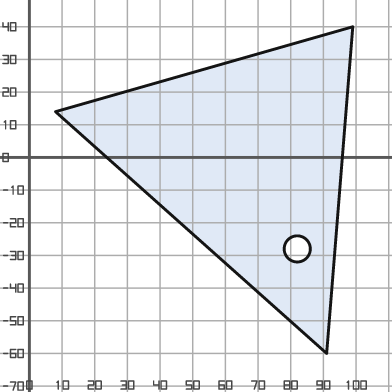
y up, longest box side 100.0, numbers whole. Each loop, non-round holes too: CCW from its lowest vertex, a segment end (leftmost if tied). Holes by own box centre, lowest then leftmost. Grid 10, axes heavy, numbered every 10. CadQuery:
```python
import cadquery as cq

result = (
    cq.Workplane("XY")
    .moveTo(91.0, -60.0)
    .lineTo(99.0, 40.0)
    .lineTo(8.0, 14.0)
    .close()
    .moveTo(82.0, -28.0)
    .circle(4.0)
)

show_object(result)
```